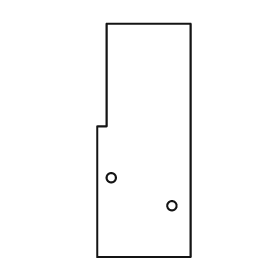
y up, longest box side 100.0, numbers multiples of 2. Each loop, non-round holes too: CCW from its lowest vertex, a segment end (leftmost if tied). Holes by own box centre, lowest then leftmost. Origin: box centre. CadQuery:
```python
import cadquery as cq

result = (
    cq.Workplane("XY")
    .moveTo(-20.0, -50.0)
    .lineTo(20.0, -50.0)
    .lineTo(20.0, 50.0)
    .lineTo(-16.0, 50.0)
    .lineTo(-16.0, 6.0)
    .lineTo(-20.0, 6.0)
    .close()
    .moveTo(12.0, -28.0)
    .circle(2.0)
    .moveTo(-14.0, -16.0)
    .circle(2.0)
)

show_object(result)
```